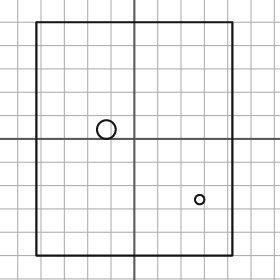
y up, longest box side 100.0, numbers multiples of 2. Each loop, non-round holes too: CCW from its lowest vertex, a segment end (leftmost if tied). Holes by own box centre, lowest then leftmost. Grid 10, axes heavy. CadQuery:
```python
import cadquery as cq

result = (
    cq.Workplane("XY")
    .moveTo(-42.0, -50.0)
    .lineTo(42.0, -50.0)
    .lineTo(42.0, 50.0)
    .lineTo(-42.0, 50.0)
    .close()
    .moveTo(28.0, -26.0)
    .circle(2.0)
    .moveTo(-12.0, 4.0)
    .circle(4.0)
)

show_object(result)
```